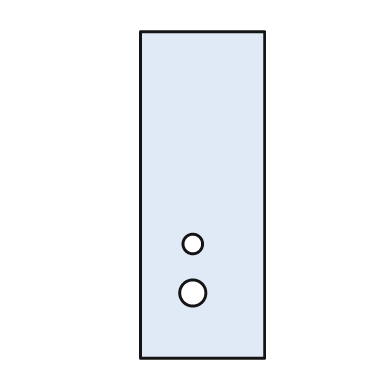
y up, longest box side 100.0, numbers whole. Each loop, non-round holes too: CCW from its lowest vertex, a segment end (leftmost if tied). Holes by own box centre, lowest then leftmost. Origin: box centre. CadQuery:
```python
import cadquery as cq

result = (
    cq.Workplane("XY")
    .moveTo(-19.0, -50.0)
    .lineTo(19.0, -50.0)
    .lineTo(19.0, 50.0)
    .lineTo(-19.0, 50.0)
    .close()
    .moveTo(-3.0, -30.0)
    .circle(4.0)
    .moveTo(-3.0, -15.0)
    .circle(3.0)
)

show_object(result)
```